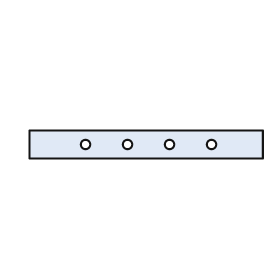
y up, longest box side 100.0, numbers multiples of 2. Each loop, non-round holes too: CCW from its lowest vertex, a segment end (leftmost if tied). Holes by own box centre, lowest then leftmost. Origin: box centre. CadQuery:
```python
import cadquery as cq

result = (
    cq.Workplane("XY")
    .moveTo(-50.0, -6.0)
    .lineTo(50.0, -6.0)
    .lineTo(50.0, 6.0)
    .lineTo(-50.0, 6.0)
    .close()
    .moveTo(-26.0, 0.0)
    .circle(2.0)
    .moveTo(-8.0, 0.0)
    .circle(2.0)
    .moveTo(10.0, 0.0)
    .circle(2.0)
    .moveTo(28.0, 0.0)
    .circle(2.0)
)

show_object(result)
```